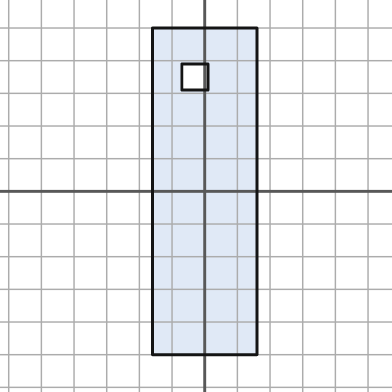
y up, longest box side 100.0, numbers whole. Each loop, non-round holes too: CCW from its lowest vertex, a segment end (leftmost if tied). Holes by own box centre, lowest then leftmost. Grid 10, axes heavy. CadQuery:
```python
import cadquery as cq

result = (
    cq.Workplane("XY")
    .moveTo(-16.0, -50.0)
    .lineTo(16.0, -50.0)
    .lineTo(16.0, 50.0)
    .lineTo(-16.0, 50.0)
    .close()
    .moveTo(-7.0, 31.0)
    .lineTo(1.0, 31.0)
    .lineTo(1.0, 39.0)
    .lineTo(-7.0, 39.0)
    .close()
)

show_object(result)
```